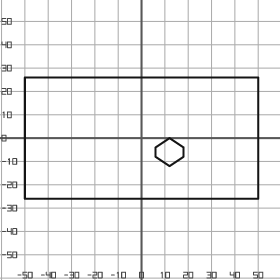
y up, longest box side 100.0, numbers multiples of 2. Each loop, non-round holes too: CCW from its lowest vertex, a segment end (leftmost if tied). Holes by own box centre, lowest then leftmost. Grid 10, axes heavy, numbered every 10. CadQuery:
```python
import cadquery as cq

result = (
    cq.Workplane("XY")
    .moveTo(-50.0, -26.0)
    .lineTo(50.0, -26.0)
    .lineTo(50.0, 26.0)
    .lineTo(-50.0, 26.0)
    .close()
    .moveTo(12.0, -12.0)
    .lineTo(18.0, -8.0)
    .lineTo(18.0, -4.0)
    .lineTo(12.0, 0.0)
    .lineTo(6.0, -4.0)
    .lineTo(6.0, -8.0)
    .close()
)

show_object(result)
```